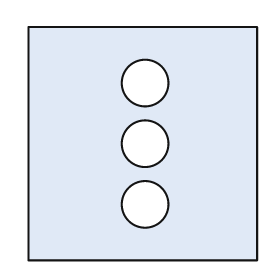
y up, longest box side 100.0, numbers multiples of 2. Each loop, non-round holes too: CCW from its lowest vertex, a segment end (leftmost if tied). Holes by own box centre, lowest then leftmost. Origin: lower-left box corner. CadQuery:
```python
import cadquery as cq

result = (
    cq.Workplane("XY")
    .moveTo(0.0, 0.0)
    .lineTo(98.0, 0.0)
    .lineTo(98.0, 100.0)
    .lineTo(0.0, 100.0)
    .close()
    .moveTo(50.0, 24.0)
    .circle(10.0)
    .moveTo(50.0, 50.0)
    .circle(10.0)
    .moveTo(50.0, 76.0)
    .circle(10.0)
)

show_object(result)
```